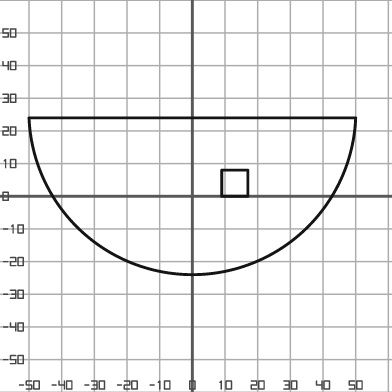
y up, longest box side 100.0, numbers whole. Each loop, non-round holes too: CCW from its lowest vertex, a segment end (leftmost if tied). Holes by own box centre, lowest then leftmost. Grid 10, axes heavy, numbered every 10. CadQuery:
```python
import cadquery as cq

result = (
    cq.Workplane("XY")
    .moveTo(-50.0, 24.0)
    .threePointArc((0.0, -24.0), (50.0, 24.0))
    .close()
    .moveTo(9.0, 0.0)
    .lineTo(17.0, 0.0)
    .lineTo(17.0, 8.0)
    .lineTo(9.0, 8.0)
    .close()
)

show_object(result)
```